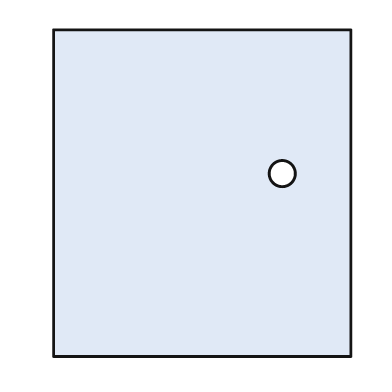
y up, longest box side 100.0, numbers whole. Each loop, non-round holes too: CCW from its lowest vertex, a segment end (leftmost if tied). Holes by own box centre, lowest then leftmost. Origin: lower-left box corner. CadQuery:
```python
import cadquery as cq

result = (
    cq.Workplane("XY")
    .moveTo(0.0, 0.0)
    .lineTo(91.0, 0.0)
    .lineTo(91.0, 100.0)
    .lineTo(0.0, 100.0)
    .close()
    .moveTo(70.0, 56.0)
    .circle(4.0)
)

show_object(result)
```